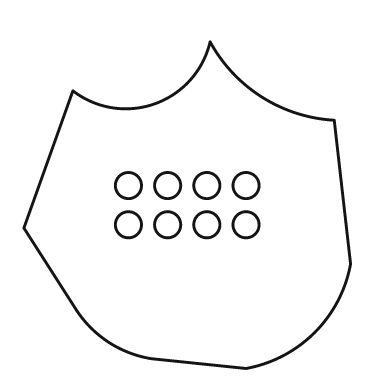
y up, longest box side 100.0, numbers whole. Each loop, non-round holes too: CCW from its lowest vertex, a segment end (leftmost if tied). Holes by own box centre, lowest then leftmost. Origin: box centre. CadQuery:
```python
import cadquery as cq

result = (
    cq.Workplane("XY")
    .moveTo(18.0, -50.0)
    .threePointArc((39.0, -39.0), (50.0, -18.0))
    .lineTo(45.0, 26.0)
    .threePointArc((23.0, 33.0), (7.0, 50.0))
    .threePointArc((-10.0, 31.0), (-35.0, 35.0))
    .lineTo(-50.0, -7.0)
    .lineTo(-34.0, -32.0)
    .threePointArc((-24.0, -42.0), (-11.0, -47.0))
    .close()
    .moveTo(-18.0, -6.0)
    .circle(4.0)
    .moveTo(-6.0, -6.0)
    .circle(4.0)
    .moveTo(6.0, -6.0)
    .circle(4.0)
    .moveTo(18.0, -6.0)
    .circle(4.0)
    .moveTo(-18.0, 6.0)
    .circle(4.0)
    .moveTo(-6.0, 6.0)
    .circle(4.0)
    .moveTo(6.0, 6.0)
    .circle(4.0)
    .moveTo(18.0, 6.0)
    .circle(4.0)
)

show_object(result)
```